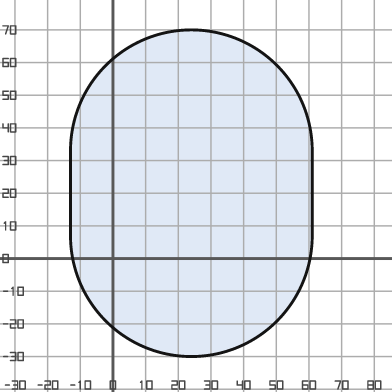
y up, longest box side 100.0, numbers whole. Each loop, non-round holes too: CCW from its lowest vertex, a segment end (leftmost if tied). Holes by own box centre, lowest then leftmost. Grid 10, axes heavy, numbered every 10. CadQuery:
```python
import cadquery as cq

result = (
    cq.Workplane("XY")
    .moveTo(-13.0, 7.0)
    .threePointArc((24.0, -30.0), (61.0, 7.0))
    .lineTo(61.0, 33.0)
    .threePointArc((24.0, 70.0), (-13.0, 33.0))
    .close()
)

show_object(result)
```